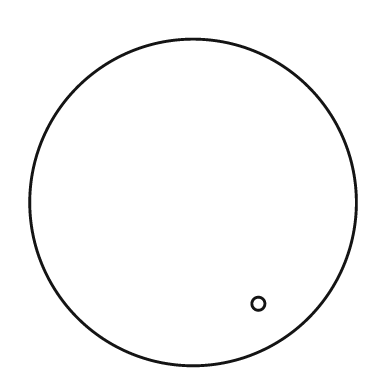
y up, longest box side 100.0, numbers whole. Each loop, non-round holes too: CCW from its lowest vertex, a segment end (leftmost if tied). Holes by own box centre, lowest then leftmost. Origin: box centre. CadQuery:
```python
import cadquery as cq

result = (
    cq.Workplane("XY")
    .moveTo(0.0, 0.0)
    .circle(50.0)
    .moveTo(20.0, -31.0)
    .circle(2.0)
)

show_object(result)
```